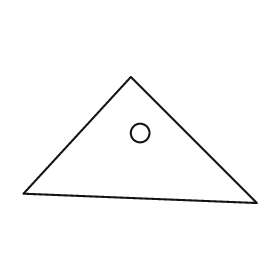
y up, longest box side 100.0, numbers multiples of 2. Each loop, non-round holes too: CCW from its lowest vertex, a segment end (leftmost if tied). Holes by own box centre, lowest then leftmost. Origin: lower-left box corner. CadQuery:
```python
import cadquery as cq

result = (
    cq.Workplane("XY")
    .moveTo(100.0, 0.0)
    .lineTo(46.0, 54.0)
    .lineTo(0.0, 4.0)
    .close()
    .moveTo(50.0, 30.0)
    .circle(4.0)
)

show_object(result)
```